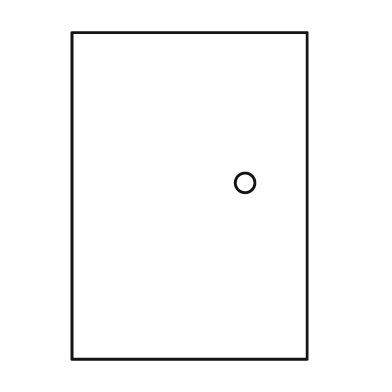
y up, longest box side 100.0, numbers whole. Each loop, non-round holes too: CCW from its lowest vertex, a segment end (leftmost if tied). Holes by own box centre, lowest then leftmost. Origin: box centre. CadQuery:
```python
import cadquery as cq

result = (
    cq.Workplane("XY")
    .moveTo(-36.0, -50.0)
    .lineTo(36.0, -50.0)
    .lineTo(36.0, 50.0)
    .lineTo(-36.0, 50.0)
    .close()
    .moveTo(17.0, 4.0)
    .circle(3.0)
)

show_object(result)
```